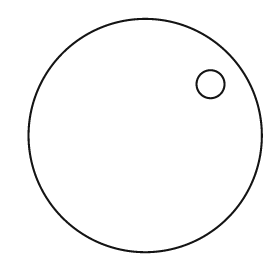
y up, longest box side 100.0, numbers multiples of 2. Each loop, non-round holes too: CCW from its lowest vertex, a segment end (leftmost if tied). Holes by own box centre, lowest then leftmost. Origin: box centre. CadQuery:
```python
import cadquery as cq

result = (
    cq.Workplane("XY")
    .moveTo(0.0, 0.0)
    .circle(50.0)
    .moveTo(28.0, 22.0)
    .circle(6.0)
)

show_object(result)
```